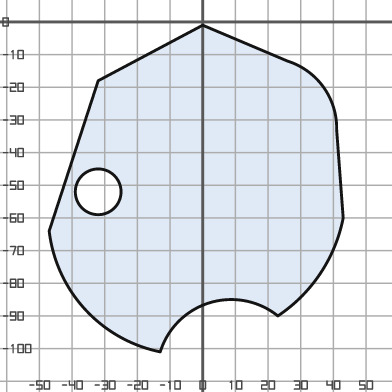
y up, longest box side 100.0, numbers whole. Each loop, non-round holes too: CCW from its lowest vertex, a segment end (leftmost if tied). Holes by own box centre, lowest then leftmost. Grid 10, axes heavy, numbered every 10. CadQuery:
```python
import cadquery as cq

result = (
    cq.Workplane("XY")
    .moveTo(-13.0, -101.0)
    .threePointArc((2.0, -86.0), (23.0, -90.0))
    .threePointArc((36.0, -77.0), (43.0, -60.0))
    .lineTo(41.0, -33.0)
    .threePointArc((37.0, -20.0), (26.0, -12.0))
    .lineTo(0.0, -1.0)
    .lineTo(-32.0, -18.0)
    .lineTo(-47.0, -64.0)
    .threePointArc((-36.0, -88.0), (-13.0, -101.0))
    .close()
    .moveTo(-32.0, -52.0)
    .circle(7.0)
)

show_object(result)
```